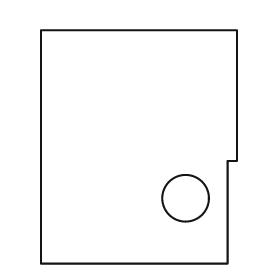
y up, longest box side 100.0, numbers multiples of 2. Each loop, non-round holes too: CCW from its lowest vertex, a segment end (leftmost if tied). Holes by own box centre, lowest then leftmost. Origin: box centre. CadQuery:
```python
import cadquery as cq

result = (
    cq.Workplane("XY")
    .moveTo(-42.0, -50.0)
    .lineTo(38.0, -50.0)
    .lineTo(38.0, -6.0)
    .lineTo(42.0, -6.0)
    .lineTo(42.0, 50.0)
    .lineTo(-42.0, 50.0)
    .close()
    .moveTo(20.0, -22.0)
    .circle(10.0)
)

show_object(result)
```